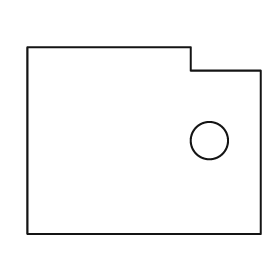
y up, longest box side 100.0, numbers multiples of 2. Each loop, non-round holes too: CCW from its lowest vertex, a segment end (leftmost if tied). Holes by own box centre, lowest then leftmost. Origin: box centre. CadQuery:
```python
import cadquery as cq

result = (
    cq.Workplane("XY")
    .moveTo(-50.0, -40.0)
    .lineTo(50.0, -40.0)
    .lineTo(50.0, 30.0)
    .lineTo(20.0, 30.0)
    .lineTo(20.0, 40.0)
    .lineTo(-50.0, 40.0)
    .close()
    .moveTo(28.0, 0.0)
    .circle(8.0)
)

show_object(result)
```